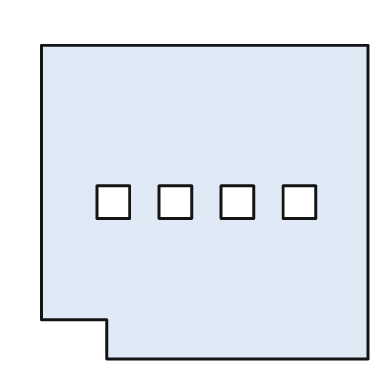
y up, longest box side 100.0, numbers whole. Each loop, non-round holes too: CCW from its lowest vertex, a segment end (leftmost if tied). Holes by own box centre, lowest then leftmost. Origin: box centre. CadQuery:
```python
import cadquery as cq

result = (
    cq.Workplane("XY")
    .moveTo(-30.0, -48.0)
    .lineTo(50.0, -48.0)
    .lineTo(50.0, 48.0)
    .lineTo(-50.0, 48.0)
    .lineTo(-50.0, -36.0)
    .lineTo(-30.0, -36.0)
    .close()
    .moveTo(-33.0, -5.0)
    .lineTo(-23.0, -5.0)
    .lineTo(-23.0, 5.0)
    .lineTo(-33.0, 5.0)
    .close()
    .moveTo(-14.0, -5.0)
    .lineTo(-4.0, -5.0)
    .lineTo(-4.0, 5.0)
    .lineTo(-14.0, 5.0)
    .close()
    .moveTo(5.0, -5.0)
    .lineTo(15.0, -5.0)
    .lineTo(15.0, 5.0)
    .lineTo(5.0, 5.0)
    .close()
    .moveTo(24.0, -5.0)
    .lineTo(34.0, -5.0)
    .lineTo(34.0, 5.0)
    .lineTo(24.0, 5.0)
    .close()
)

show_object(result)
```